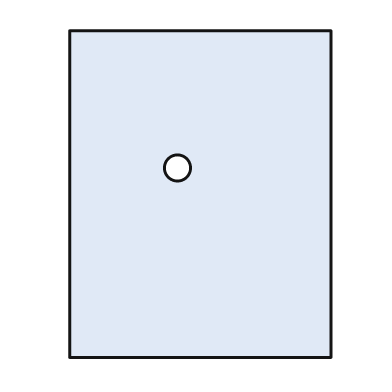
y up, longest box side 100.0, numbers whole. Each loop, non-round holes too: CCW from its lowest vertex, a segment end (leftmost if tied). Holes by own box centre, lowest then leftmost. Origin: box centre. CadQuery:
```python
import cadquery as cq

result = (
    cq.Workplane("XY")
    .moveTo(-40.0, -50.0)
    .lineTo(40.0, -50.0)
    .lineTo(40.0, 50.0)
    .lineTo(-40.0, 50.0)
    .close()
    .moveTo(-7.0, 8.0)
    .circle(4.0)
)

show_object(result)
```